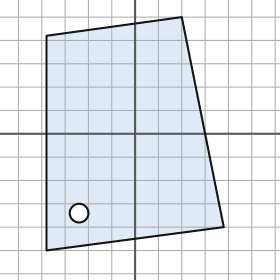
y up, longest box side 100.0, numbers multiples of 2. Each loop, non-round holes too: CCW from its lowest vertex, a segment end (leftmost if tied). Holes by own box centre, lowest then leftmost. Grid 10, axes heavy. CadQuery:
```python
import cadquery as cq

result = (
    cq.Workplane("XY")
    .moveTo(-38.0, -50.0)
    .lineTo(38.0, -40.0)
    .lineTo(20.0, 50.0)
    .lineTo(-38.0, 42.0)
    .close()
    .moveTo(-24.0, -34.0)
    .circle(4.0)
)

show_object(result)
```